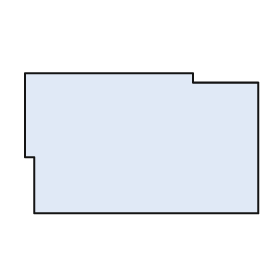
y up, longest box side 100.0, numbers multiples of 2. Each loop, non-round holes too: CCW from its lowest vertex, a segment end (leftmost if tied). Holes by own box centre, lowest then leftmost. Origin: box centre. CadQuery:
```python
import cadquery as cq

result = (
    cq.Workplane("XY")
    .moveTo(-46.0, -30.0)
    .lineTo(50.0, -30.0)
    .lineTo(50.0, 26.0)
    .lineTo(22.0, 26.0)
    .lineTo(22.0, 30.0)
    .lineTo(-50.0, 30.0)
    .lineTo(-50.0, -6.0)
    .lineTo(-46.0, -6.0)
    .close()
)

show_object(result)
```